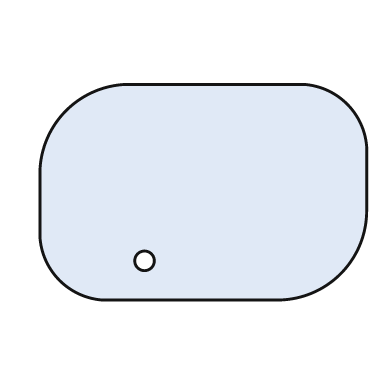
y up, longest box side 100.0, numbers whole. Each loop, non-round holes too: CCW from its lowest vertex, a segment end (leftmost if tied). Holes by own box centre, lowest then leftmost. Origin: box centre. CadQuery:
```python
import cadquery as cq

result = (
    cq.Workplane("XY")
    .moveTo(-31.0, -33.0)
    .lineTo(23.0, -33.0)
    .threePointArc((42.0, -25.0), (50.0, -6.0))
    .lineTo(50.0, 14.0)
    .threePointArc((44.0, 27.0), (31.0, 33.0))
    .lineTo(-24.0, 33.0)
    .threePointArc((-42.0, 25.0), (-50.0, 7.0))
    .lineTo(-50.0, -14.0)
    .threePointArc((-44.0, -27.0), (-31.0, -33.0))
    .close()
    .moveTo(-18.0, -21.0)
    .circle(3.0)
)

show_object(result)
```